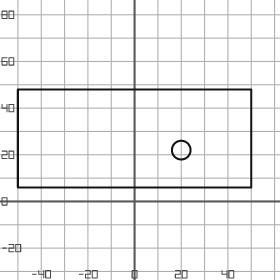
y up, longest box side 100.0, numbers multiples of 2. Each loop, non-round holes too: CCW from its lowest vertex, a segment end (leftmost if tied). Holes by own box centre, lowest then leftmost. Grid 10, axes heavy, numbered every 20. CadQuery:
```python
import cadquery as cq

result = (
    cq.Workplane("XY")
    .moveTo(-50.0, 6.0)
    .lineTo(50.0, 6.0)
    .lineTo(50.0, 48.0)
    .lineTo(-50.0, 48.0)
    .close()
    .moveTo(20.0, 22.0)
    .circle(4.0)
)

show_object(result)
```